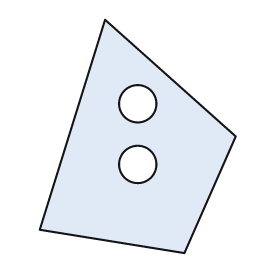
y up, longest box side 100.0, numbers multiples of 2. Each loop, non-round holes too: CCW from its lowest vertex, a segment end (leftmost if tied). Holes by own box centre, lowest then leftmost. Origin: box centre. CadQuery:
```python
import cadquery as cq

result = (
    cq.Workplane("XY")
    .moveTo(20.0, -50.0)
    .lineTo(42.0, 0.0)
    .lineTo(-14.0, 50.0)
    .lineTo(-42.0, -40.0)
    .close()
    .moveTo(0.0, -12.0)
    .circle(8.0)
    .moveTo(0.0, 14.0)
    .circle(8.0)
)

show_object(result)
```